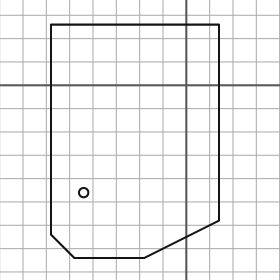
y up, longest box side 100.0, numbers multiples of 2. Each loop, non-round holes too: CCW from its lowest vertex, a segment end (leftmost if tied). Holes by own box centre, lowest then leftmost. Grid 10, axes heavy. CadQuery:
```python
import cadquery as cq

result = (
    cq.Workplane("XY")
    .moveTo(-48.0, -74.0)
    .lineTo(-18.0, -74.0)
    .lineTo(14.0, -58.0)
    .lineTo(14.0, 26.0)
    .lineTo(-58.0, 26.0)
    .lineTo(-58.0, -64.0)
    .close()
    .moveTo(-44.0, -46.0)
    .circle(2.0)
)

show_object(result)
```